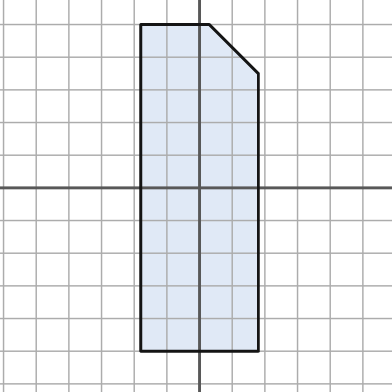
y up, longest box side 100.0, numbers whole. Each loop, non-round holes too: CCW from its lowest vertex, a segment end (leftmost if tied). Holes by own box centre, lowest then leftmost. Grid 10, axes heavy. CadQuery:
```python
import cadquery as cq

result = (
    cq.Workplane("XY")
    .moveTo(-18.0, -50.0)
    .lineTo(18.0, -50.0)
    .lineTo(18.0, 35.0)
    .lineTo(3.0, 50.0)
    .lineTo(-18.0, 50.0)
    .close()
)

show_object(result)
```